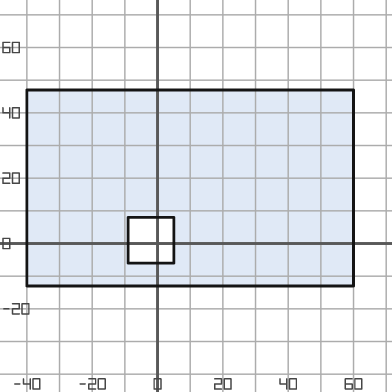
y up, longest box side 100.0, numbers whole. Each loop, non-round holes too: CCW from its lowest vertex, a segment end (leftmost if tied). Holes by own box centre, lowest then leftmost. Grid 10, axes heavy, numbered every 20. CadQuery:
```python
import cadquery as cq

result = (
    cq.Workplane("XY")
    .moveTo(-40.0, -13.0)
    .lineTo(60.0, -13.0)
    .lineTo(60.0, 47.0)
    .lineTo(-40.0, 47.0)
    .close()
    .moveTo(-9.0, -6.0)
    .lineTo(5.0, -6.0)
    .lineTo(5.0, 8.0)
    .lineTo(-9.0, 8.0)
    .close()
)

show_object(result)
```